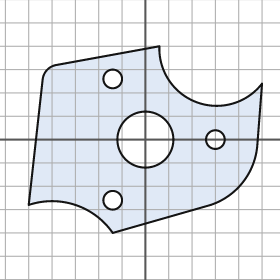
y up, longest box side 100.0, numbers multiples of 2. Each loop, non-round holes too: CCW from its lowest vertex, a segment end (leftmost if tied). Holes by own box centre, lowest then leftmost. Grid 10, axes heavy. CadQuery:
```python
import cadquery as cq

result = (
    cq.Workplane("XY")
    .moveTo(-14.0, -40.0)
    .lineTo(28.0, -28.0)
    .threePointArc((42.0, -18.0), (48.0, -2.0))
    .lineTo(50.0, 24.0)
    .threePointArc((22.0, 16.0), (6.0, 40.0))
    .lineTo(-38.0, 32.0)
    .threePointArc((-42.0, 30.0), (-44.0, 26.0))
    .lineTo(-50.0, -28.0)
    .threePointArc((-30.0, -28.0), (-14.0, -40.0))
    .close()
    .moveTo(-14.0, -26.0)
    .circle(4.0)
    .moveTo(0.0, 0.0)
    .circle(12.0)
    .moveTo(30.0, 0.0)
    .circle(4.0)
    .moveTo(-14.0, 26.0)
    .circle(4.0)
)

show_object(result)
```